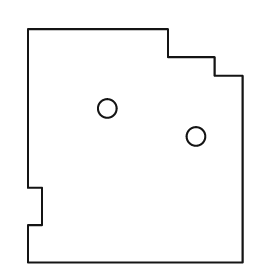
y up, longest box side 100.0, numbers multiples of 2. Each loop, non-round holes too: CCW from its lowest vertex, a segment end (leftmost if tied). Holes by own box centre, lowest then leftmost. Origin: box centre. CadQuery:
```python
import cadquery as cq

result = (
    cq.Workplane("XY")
    .moveTo(-46.0, -50.0)
    .lineTo(46.0, -50.0)
    .lineTo(46.0, 30.0)
    .lineTo(34.0, 30.0)
    .lineTo(34.0, 38.0)
    .lineTo(14.0, 38.0)
    .lineTo(14.0, 50.0)
    .lineTo(-46.0, 50.0)
    .lineTo(-46.0, -18.0)
    .lineTo(-40.0, -18.0)
    .lineTo(-40.0, -34.0)
    .lineTo(-46.0, -34.0)
    .close()
    .moveTo(26.0, 4.0)
    .circle(4.0)
    .moveTo(-12.0, 16.0)
    .circle(4.0)
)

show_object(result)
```